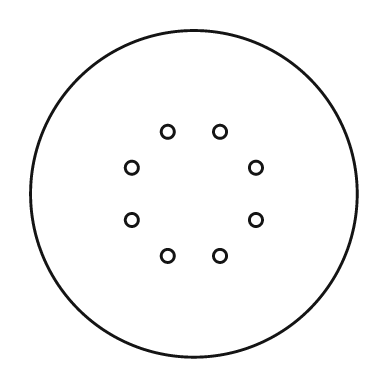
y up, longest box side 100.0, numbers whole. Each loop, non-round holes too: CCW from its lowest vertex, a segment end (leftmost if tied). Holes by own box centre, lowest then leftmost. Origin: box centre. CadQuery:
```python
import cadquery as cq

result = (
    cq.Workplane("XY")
    .moveTo(0.0, 0.0)
    .circle(50.0)
    .moveTo(-8.0, -19.0)
    .circle(2.0)
    .moveTo(8.0, -19.0)
    .circle(2.0)
    .moveTo(-19.0, -8.0)
    .circle(2.0)
    .moveTo(19.0, -8.0)
    .circle(2.0)
    .moveTo(-19.0, 8.0)
    .circle(2.0)
    .moveTo(19.0, 8.0)
    .circle(2.0)
    .moveTo(-8.0, 19.0)
    .circle(2.0)
    .moveTo(8.0, 19.0)
    .circle(2.0)
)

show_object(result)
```